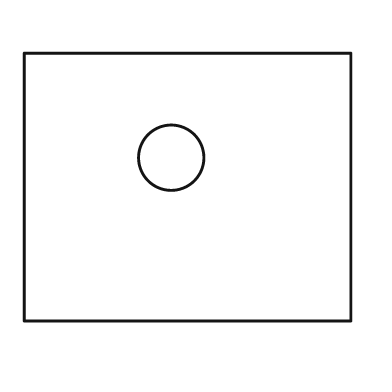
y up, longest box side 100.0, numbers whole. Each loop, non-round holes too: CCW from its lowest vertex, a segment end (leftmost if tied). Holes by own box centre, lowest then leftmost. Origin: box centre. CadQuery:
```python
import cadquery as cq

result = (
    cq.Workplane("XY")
    .moveTo(-50.0, -41.0)
    .lineTo(50.0, -41.0)
    .lineTo(50.0, 41.0)
    .lineTo(-50.0, 41.0)
    .close()
    .moveTo(-5.0, 9.0)
    .circle(10.0)
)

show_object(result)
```